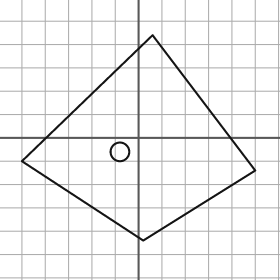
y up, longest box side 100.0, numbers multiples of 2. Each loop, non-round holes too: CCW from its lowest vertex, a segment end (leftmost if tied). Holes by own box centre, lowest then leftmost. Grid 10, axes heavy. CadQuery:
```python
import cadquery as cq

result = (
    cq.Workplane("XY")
    .moveTo(2.0, -44.0)
    .lineTo(50.0, -14.0)
    .lineTo(6.0, 44.0)
    .lineTo(-50.0, -10.0)
    .close()
    .moveTo(-8.0, -6.0)
    .circle(4.0)
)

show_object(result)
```